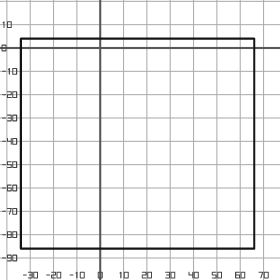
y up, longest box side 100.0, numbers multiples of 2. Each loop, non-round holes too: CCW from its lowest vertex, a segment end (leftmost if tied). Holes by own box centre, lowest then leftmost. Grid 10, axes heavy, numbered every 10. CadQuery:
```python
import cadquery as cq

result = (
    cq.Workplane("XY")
    .moveTo(-34.0, -86.0)
    .lineTo(66.0, -86.0)
    .lineTo(66.0, 4.0)
    .lineTo(-34.0, 4.0)
    .close()
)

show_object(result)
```